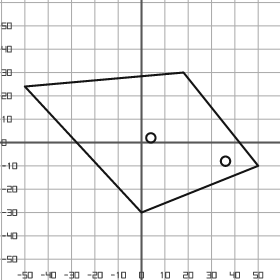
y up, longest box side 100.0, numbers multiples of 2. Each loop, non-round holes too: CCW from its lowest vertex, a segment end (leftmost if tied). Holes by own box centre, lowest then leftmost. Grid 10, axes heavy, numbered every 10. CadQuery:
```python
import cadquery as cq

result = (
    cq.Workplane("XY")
    .moveTo(0.0, -30.0)
    .lineTo(50.0, -10.0)
    .lineTo(18.0, 30.0)
    .lineTo(-50.0, 24.0)
    .close()
    .moveTo(36.0, -8.0)
    .circle(2.0)
    .moveTo(4.0, 2.0)
    .circle(2.0)
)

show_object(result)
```